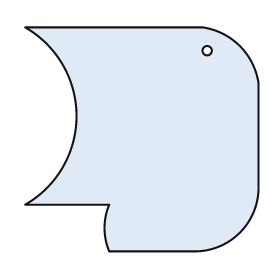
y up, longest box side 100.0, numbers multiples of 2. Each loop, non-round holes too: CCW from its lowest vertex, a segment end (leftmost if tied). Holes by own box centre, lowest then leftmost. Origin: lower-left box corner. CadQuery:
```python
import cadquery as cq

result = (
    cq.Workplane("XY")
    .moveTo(36.0, 0.0)
    .lineTo(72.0, 0.0)
    .threePointArc((92.0, 8.0), (100.0, 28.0))
    .lineTo(100.0, 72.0)
    .threePointArc((92.0, 88.0), (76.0, 96.0))
    .lineTo(0.0, 96.0)
    .threePointArc((22.0, 58.0), (0.0, 20.0))
    .lineTo(36.0, 20.0)
    .threePointArc((34.0, 10.0), (36.0, 0.0))
    .close()
    .moveTo(78.0, 86.0)
    .circle(2.0)
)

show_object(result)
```